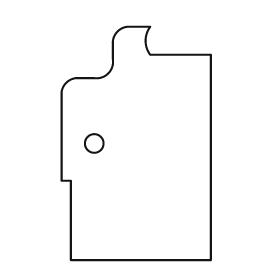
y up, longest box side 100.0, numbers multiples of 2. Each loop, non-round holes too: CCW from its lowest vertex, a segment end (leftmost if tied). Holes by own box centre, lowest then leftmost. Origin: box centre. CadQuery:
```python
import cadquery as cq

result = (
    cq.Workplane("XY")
    .moveTo(-28.0, -50.0)
    .lineTo(32.0, -50.0)
    .lineTo(32.0, 38.0)
    .lineTo(6.0, 38.0)
    .threePointArc((4.0, 44.0), (6.0, 50.0))
    .lineTo(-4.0, 50.0)
    .threePointArc((-8.0, 48.0), (-10.0, 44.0))
    .lineTo(-10.0, 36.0)
    .threePointArc((-12.0, 30.0), (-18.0, 28.0))
    .lineTo(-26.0, 28.0)
    .threePointArc((-30.0, 26.0), (-32.0, 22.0))
    .lineTo(-32.0, -16.0)
    .lineTo(-28.0, -16.0)
    .close()
    .moveTo(-18.0, 0.0)
    .circle(4.0)
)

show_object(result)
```